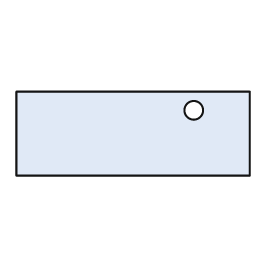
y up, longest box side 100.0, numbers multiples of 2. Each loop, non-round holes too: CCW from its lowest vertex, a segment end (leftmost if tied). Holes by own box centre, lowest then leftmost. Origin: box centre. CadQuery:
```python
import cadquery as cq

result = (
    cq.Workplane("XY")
    .moveTo(-50.0, -18.0)
    .lineTo(50.0, -18.0)
    .lineTo(50.0, 18.0)
    .lineTo(-50.0, 18.0)
    .close()
    .moveTo(26.0, 10.0)
    .circle(4.0)
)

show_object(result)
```